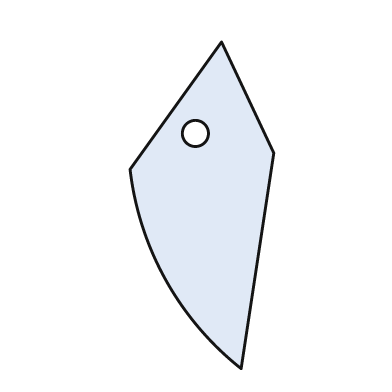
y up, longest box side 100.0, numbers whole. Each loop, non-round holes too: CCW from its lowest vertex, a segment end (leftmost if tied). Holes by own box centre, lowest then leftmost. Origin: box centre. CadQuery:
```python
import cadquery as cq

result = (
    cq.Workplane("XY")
    .moveTo(12.0, -50.0)
    .lineTo(22.0, 16.0)
    .lineTo(6.0, 50.0)
    .lineTo(-22.0, 11.0)
    .threePointArc((-11.0, -23.0), (12.0, -50.0))
    .close()
    .moveTo(-2.0, 22.0)
    .circle(4.0)
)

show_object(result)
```